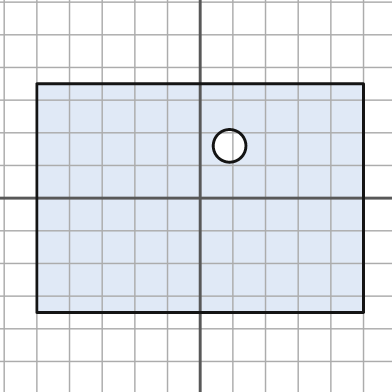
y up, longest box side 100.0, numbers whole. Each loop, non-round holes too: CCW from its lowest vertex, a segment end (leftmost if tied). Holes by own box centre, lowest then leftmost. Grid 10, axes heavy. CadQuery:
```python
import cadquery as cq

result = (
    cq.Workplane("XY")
    .moveTo(-50.0, -35.0)
    .lineTo(50.0, -35.0)
    .lineTo(50.0, 35.0)
    .lineTo(-50.0, 35.0)
    .close()
    .moveTo(9.0, 16.0)
    .circle(5.0)
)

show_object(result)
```